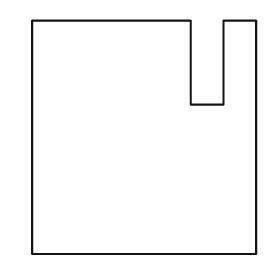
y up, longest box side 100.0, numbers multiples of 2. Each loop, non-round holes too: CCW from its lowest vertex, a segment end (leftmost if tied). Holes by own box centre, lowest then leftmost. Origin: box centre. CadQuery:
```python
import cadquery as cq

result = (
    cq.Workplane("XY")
    .moveTo(-48.0, -50.0)
    .lineTo(48.0, -50.0)
    .lineTo(48.0, 50.0)
    .lineTo(34.0, 50.0)
    .lineTo(34.0, 14.0)
    .lineTo(20.0, 14.0)
    .lineTo(20.0, 50.0)
    .lineTo(-48.0, 50.0)
    .close()
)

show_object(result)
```